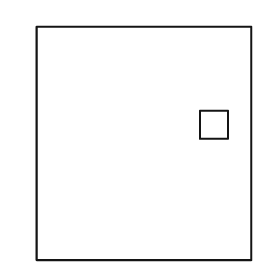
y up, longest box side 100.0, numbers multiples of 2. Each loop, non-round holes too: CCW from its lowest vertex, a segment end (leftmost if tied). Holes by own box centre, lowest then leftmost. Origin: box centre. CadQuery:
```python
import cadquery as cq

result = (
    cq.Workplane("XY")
    .moveTo(-46.0, -50.0)
    .lineTo(46.0, -50.0)
    .lineTo(46.0, 50.0)
    .lineTo(-46.0, 50.0)
    .close()
    .moveTo(24.0, 2.0)
    .lineTo(36.0, 2.0)
    .lineTo(36.0, 14.0)
    .lineTo(24.0, 14.0)
    .close()
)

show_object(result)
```